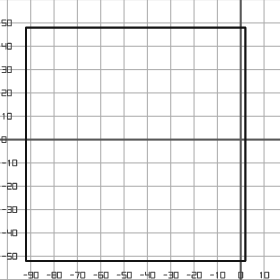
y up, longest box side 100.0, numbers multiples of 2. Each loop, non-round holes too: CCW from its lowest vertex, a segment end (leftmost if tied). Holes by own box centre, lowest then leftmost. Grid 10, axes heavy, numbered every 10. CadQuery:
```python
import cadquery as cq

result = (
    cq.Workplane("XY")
    .moveTo(-92.0, -52.0)
    .lineTo(2.0, -52.0)
    .lineTo(2.0, 48.0)
    .lineTo(-92.0, 48.0)
    .close()
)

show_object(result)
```